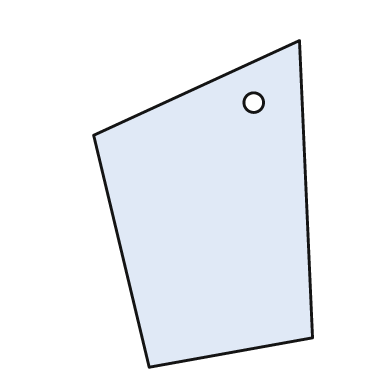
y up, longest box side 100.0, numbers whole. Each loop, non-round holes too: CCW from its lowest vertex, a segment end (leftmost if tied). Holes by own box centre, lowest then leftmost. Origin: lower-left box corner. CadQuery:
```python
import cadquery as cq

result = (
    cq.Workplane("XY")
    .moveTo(17.0, 0.0)
    .lineTo(67.0, 9.0)
    .lineTo(63.0, 100.0)
    .lineTo(0.0, 71.0)
    .close()
    .moveTo(49.0, 81.0)
    .circle(3.0)
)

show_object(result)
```